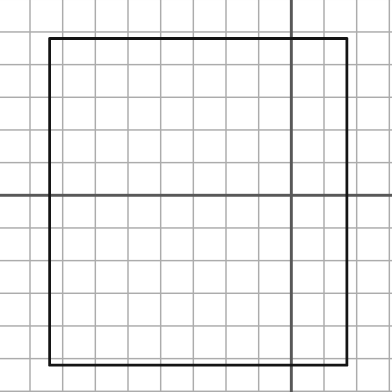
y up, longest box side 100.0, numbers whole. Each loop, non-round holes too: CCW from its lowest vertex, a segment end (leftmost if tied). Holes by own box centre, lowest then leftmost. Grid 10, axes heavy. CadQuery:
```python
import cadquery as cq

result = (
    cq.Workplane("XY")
    .moveTo(-74.0, -52.0)
    .lineTo(17.0, -52.0)
    .lineTo(17.0, 48.0)
    .lineTo(-74.0, 48.0)
    .close()
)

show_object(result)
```